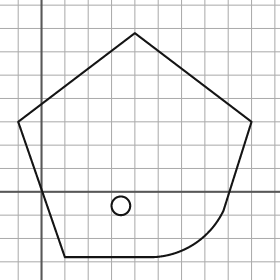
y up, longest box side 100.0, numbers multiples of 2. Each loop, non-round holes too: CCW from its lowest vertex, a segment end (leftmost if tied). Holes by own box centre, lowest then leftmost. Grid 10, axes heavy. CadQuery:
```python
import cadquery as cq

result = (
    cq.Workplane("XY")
    .moveTo(10.0, -28.0)
    .lineTo(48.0, -28.0)
    .threePointArc((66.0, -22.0), (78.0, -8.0))
    .lineTo(90.0, 30.0)
    .lineTo(40.0, 68.0)
    .lineTo(-10.0, 30.0)
    .close()
    .moveTo(34.0, -6.0)
    .circle(4.0)
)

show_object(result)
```